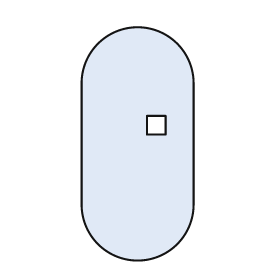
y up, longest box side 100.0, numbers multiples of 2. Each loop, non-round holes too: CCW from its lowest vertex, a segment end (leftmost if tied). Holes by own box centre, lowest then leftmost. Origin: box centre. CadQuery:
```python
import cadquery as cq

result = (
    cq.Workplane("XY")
    .moveTo(-24.0, -26.0)
    .threePointArc((0.0, -50.0), (24.0, -26.0))
    .lineTo(24.0, 26.0)
    .threePointArc((0.0, 50.0), (-24.0, 26.0))
    .close()
    .moveTo(4.0, 4.0)
    .lineTo(12.0, 4.0)
    .lineTo(12.0, 12.0)
    .lineTo(4.0, 12.0)
    .close()
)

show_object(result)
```